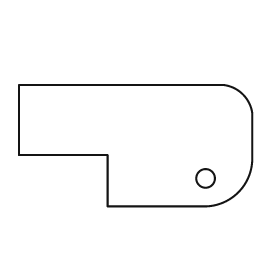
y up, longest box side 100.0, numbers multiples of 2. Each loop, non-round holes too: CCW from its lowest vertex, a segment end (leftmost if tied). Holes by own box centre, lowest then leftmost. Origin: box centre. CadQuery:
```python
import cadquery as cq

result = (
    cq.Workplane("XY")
    .moveTo(-12.0, -26.0)
    .lineTo(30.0, -26.0)
    .threePointArc((44.0, -20.0), (50.0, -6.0))
    .lineTo(50.0, 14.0)
    .threePointArc((46.0, 22.0), (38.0, 26.0))
    .lineTo(-50.0, 26.0)
    .lineTo(-50.0, -4.0)
    .lineTo(-12.0, -4.0)
    .close()
    .moveTo(30.0, -14.0)
    .circle(4.0)
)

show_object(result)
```